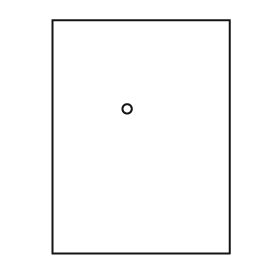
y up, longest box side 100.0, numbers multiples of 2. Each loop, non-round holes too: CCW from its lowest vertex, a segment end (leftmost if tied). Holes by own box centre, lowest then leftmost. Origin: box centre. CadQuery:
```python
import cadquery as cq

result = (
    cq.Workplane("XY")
    .moveTo(-38.0, -50.0)
    .lineTo(38.0, -50.0)
    .lineTo(38.0, 50.0)
    .lineTo(-38.0, 50.0)
    .close()
    .moveTo(-6.0, 12.0)
    .circle(2.0)
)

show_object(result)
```